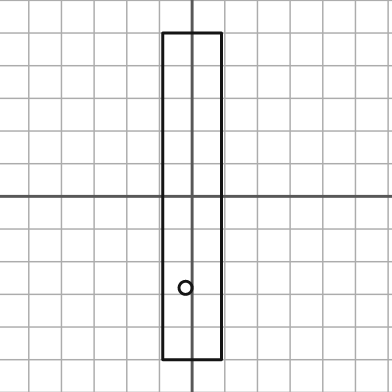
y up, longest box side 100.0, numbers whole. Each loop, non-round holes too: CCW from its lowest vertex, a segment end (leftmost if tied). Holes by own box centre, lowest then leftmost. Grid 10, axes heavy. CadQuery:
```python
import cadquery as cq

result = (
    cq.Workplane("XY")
    .moveTo(-9.0, -50.0)
    .lineTo(9.0, -50.0)
    .lineTo(9.0, 50.0)
    .lineTo(-9.0, 50.0)
    .close()
    .moveTo(-2.0, -28.0)
    .circle(2.0)
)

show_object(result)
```